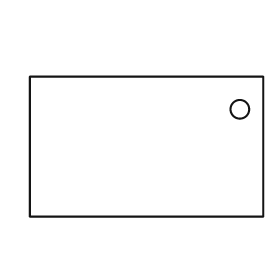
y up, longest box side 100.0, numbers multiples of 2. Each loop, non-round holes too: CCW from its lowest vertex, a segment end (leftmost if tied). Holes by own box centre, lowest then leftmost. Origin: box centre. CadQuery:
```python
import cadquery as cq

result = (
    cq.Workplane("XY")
    .moveTo(-50.0, -30.0)
    .lineTo(50.0, -30.0)
    .lineTo(50.0, 30.0)
    .lineTo(-50.0, 30.0)
    .close()
    .moveTo(40.0, 16.0)
    .circle(4.0)
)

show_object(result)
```